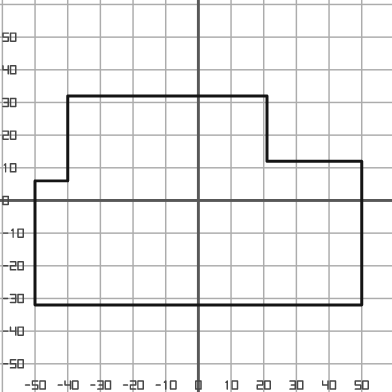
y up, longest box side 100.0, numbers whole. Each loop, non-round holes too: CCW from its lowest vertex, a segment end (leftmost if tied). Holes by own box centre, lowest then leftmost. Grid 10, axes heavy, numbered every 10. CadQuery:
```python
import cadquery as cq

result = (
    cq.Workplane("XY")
    .moveTo(-50.0, -32.0)
    .lineTo(50.0, -32.0)
    .lineTo(50.0, 12.0)
    .lineTo(21.0, 12.0)
    .lineTo(21.0, 32.0)
    .lineTo(-40.0, 32.0)
    .lineTo(-40.0, 6.0)
    .lineTo(-50.0, 6.0)
    .close()
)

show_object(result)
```